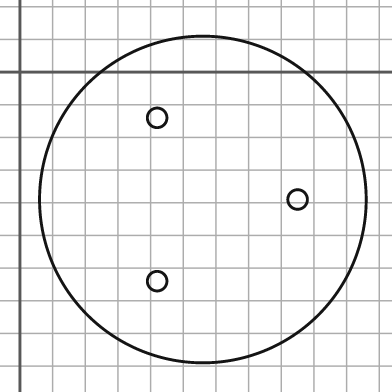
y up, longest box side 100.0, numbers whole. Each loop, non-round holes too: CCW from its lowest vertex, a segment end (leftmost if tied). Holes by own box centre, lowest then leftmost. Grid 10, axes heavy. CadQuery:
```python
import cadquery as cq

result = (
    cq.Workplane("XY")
    .moveTo(56.0, -39.0)
    .circle(50.0)
    .moveTo(42.0, -64.0)
    .circle(3.0)
    .moveTo(85.0, -39.0)
    .circle(3.0)
    .moveTo(42.0, -14.0)
    .circle(3.0)
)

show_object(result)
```